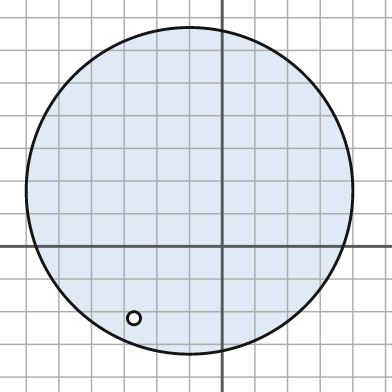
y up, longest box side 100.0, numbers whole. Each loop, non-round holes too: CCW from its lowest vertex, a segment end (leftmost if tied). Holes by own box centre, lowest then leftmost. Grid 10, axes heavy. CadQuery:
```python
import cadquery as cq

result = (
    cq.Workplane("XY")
    .moveTo(-10.0, 17.0)
    .circle(50.0)
    .moveTo(-27.0, -22.0)
    .circle(2.0)
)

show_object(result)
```